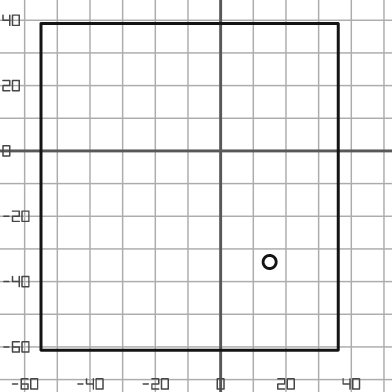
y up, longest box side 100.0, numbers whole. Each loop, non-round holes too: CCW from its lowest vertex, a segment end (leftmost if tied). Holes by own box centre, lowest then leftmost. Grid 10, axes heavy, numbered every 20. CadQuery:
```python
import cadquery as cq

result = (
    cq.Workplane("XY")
    .moveTo(-55.0, -61.0)
    .lineTo(36.0, -61.0)
    .lineTo(36.0, 39.0)
    .lineTo(-55.0, 39.0)
    .close()
    .moveTo(15.0, -34.0)
    .circle(2.0)
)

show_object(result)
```